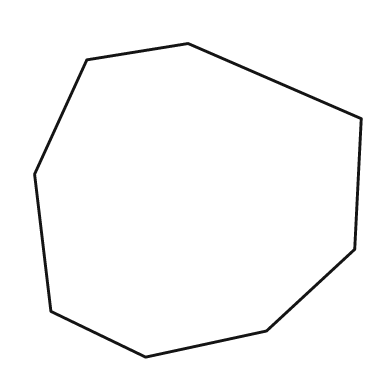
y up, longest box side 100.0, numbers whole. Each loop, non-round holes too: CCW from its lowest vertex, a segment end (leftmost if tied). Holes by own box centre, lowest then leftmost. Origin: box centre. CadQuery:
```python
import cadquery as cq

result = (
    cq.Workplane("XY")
    .moveTo(-16.0, -48.0)
    .lineTo(21.0, -40.0)
    .lineTo(48.0, -15.0)
    .lineTo(50.0, 25.0)
    .lineTo(-3.0, 48.0)
    .lineTo(-34.0, 43.0)
    .lineTo(-50.0, 8.0)
    .lineTo(-45.0, -34.0)
    .close()
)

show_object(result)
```